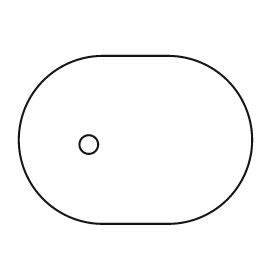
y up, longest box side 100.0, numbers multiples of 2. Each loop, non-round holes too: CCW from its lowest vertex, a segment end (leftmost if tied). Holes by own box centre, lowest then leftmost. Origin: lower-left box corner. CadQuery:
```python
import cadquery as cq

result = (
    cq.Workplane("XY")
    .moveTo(36.0, 0.0)
    .lineTo(64.0, 0.0)
    .threePointArc((100.0, 36.0), (64.0, 72.0))
    .lineTo(36.0, 72.0)
    .threePointArc((0.0, 36.0), (36.0, 0.0))
    .close()
    .moveTo(30.0, 34.0)
    .circle(4.0)
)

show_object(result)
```